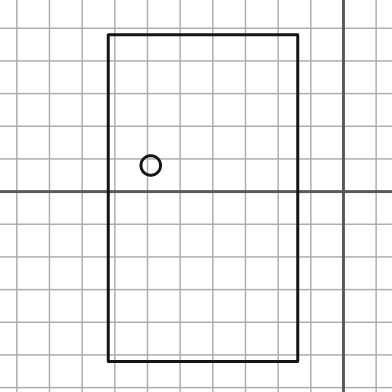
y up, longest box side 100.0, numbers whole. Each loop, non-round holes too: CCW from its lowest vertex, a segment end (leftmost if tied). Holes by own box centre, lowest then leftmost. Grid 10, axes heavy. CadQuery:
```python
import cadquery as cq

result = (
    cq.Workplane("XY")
    .moveTo(-72.0, -52.0)
    .lineTo(-14.0, -52.0)
    .lineTo(-14.0, 48.0)
    .lineTo(-72.0, 48.0)
    .close()
    .moveTo(-59.0, 8.0)
    .circle(3.0)
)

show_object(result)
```